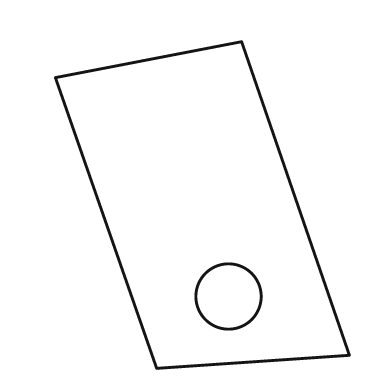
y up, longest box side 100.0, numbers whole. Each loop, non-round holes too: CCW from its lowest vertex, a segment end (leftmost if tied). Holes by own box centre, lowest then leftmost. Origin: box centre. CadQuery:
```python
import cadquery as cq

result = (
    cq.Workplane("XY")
    .moveTo(-14.0, -50.0)
    .lineTo(45.0, -46.0)
    .lineTo(12.0, 50.0)
    .lineTo(-45.0, 39.0)
    .close()
    .moveTo(8.0, -28.0)
    .circle(10.0)
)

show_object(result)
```